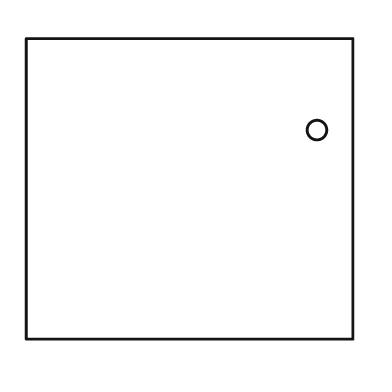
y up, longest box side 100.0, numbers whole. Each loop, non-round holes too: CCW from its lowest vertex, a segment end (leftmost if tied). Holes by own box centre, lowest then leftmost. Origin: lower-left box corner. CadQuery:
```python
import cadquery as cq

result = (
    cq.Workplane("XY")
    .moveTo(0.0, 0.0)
    .lineTo(100.0, 0.0)
    .lineTo(100.0, 92.0)
    .lineTo(0.0, 92.0)
    .close()
    .moveTo(89.0, 64.0)
    .circle(3.0)
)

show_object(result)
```